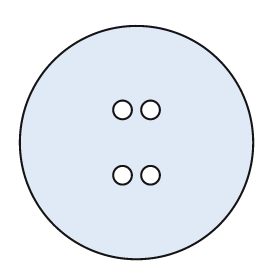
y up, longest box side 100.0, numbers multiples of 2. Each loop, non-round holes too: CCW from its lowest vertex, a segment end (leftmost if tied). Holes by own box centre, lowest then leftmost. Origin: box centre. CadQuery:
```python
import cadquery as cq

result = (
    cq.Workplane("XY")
    .moveTo(0.0, 0.0)
    .circle(50.0)
    .moveTo(-6.0, -14.0)
    .circle(4.0)
    .moveTo(6.0, -14.0)
    .circle(4.0)
    .moveTo(-6.0, 14.0)
    .circle(4.0)
    .moveTo(6.0, 14.0)
    .circle(4.0)
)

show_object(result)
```